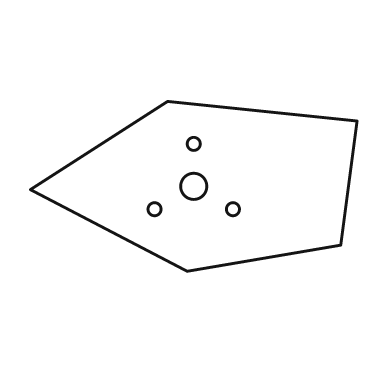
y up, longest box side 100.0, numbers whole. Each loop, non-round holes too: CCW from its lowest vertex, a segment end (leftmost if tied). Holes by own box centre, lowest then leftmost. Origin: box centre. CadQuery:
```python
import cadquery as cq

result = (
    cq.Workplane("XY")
    .moveTo(-2.0, -26.0)
    .lineTo(45.0, -18.0)
    .lineTo(50.0, 20.0)
    .lineTo(-8.0, 26.0)
    .lineTo(-50.0, -1.0)
    .close()
    .moveTo(-12.0, -7.0)
    .circle(2.0)
    .moveTo(12.0, -7.0)
    .circle(2.0)
    .moveTo(0.0, 0.0)
    .circle(4.0)
    .moveTo(0.0, 13.0)
    .circle(2.0)
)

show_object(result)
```